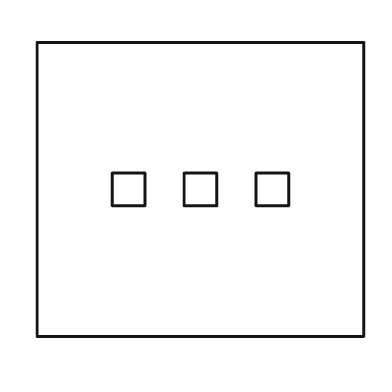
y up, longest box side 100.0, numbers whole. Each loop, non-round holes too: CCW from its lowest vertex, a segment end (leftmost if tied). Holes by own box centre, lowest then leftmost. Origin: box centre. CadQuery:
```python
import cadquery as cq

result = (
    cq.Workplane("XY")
    .moveTo(-50.0, -45.0)
    .lineTo(50.0, -45.0)
    .lineTo(50.0, 45.0)
    .lineTo(-50.0, 45.0)
    .close()
    .moveTo(-27.0, -5.0)
    .lineTo(-17.0, -5.0)
    .lineTo(-17.0, 5.0)
    .lineTo(-27.0, 5.0)
    .close()
    .moveTo(-5.0, -5.0)
    .lineTo(5.0, -5.0)
    .lineTo(5.0, 5.0)
    .lineTo(-5.0, 5.0)
    .close()
    .moveTo(17.0, -5.0)
    .lineTo(27.0, -5.0)
    .lineTo(27.0, 5.0)
    .lineTo(17.0, 5.0)
    .close()
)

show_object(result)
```